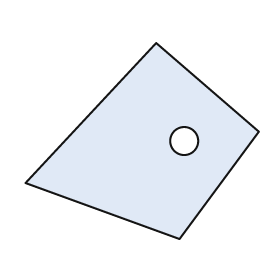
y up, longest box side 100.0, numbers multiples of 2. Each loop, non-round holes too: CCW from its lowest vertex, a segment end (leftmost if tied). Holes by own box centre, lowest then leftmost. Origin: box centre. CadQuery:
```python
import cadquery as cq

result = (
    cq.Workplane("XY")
    .moveTo(16.0, -42.0)
    .lineTo(50.0, 4.0)
    .lineTo(6.0, 42.0)
    .lineTo(-50.0, -18.0)
    .close()
    .moveTo(18.0, 0.0)
    .circle(6.0)
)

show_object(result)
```